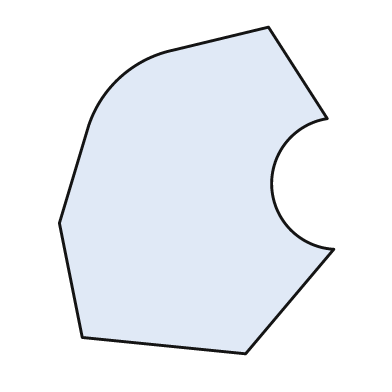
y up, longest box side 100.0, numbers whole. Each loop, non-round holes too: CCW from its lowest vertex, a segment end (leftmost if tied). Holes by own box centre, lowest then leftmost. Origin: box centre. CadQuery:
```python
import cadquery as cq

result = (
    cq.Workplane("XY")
    .moveTo(15.0, -50.0)
    .lineTo(42.0, -18.0)
    .threePointArc((23.0, 1.0), (40.0, 22.0))
    .lineTo(22.0, 50.0)
    .lineTo(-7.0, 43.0)
    .threePointArc((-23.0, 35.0), (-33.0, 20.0))
    .lineTo(-42.0, -10.0)
    .lineTo(-35.0, -45.0)
    .close()
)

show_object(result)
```